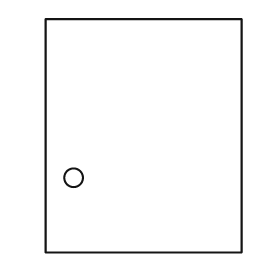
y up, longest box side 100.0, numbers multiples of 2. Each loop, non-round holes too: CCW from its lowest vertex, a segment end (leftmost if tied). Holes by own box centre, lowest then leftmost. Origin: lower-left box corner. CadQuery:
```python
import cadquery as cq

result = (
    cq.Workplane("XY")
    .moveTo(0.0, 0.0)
    .lineTo(84.0, 0.0)
    .lineTo(84.0, 100.0)
    .lineTo(0.0, 100.0)
    .close()
    .moveTo(12.0, 32.0)
    .circle(4.0)
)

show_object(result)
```